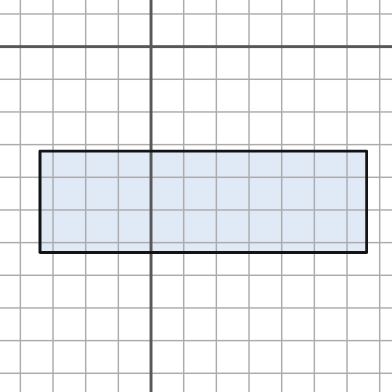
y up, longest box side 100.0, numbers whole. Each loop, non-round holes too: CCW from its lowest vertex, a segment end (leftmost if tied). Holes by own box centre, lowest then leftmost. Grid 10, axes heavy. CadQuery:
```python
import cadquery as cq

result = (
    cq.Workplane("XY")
    .moveTo(-34.0, -63.0)
    .lineTo(66.0, -63.0)
    .lineTo(66.0, -32.0)
    .lineTo(-34.0, -32.0)
    .close()
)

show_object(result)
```